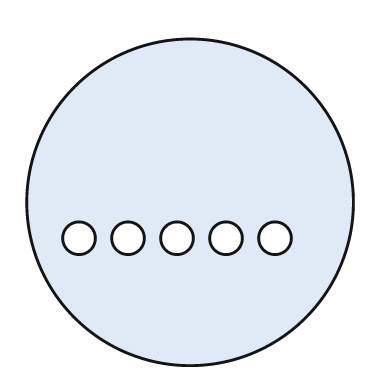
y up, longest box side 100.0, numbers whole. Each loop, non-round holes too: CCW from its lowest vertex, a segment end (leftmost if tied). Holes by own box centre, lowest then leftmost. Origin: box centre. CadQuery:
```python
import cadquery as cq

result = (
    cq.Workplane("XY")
    .moveTo(0.0, 0.0)
    .circle(50.0)
    .moveTo(-34.0, -11.0)
    .circle(5.0)
    .moveTo(-19.0, -11.0)
    .circle(5.0)
    .moveTo(-4.0, -11.0)
    .circle(5.0)
    .moveTo(11.0, -11.0)
    .circle(5.0)
    .moveTo(26.0, -11.0)
    .circle(5.0)
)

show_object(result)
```